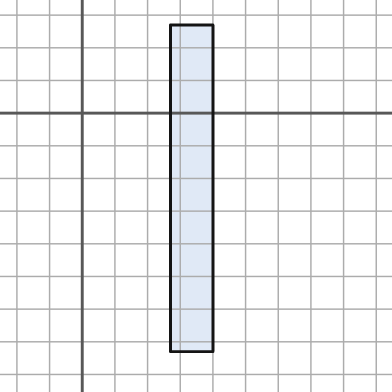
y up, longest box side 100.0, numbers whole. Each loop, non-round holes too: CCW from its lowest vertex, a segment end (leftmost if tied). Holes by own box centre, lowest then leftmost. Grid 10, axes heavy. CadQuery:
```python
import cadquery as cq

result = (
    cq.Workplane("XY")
    .moveTo(27.0, -73.0)
    .lineTo(40.0, -73.0)
    .lineTo(40.0, 27.0)
    .lineTo(27.0, 27.0)
    .close()
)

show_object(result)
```